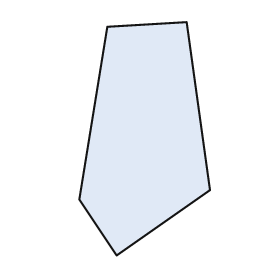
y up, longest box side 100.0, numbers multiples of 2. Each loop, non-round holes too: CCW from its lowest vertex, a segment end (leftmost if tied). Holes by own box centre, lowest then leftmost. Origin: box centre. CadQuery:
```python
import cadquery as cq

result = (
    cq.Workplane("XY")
    .moveTo(-12.0, -50.0)
    .lineTo(28.0, -22.0)
    .lineTo(18.0, 50.0)
    .lineTo(-16.0, 48.0)
    .lineTo(-28.0, -26.0)
    .close()
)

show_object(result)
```